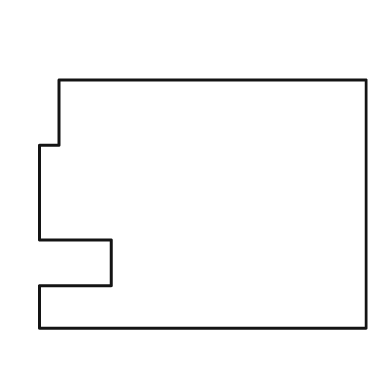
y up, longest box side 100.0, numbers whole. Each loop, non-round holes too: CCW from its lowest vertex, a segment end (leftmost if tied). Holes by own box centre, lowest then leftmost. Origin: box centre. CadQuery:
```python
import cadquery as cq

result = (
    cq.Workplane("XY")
    .moveTo(-50.0, -38.0)
    .lineTo(50.0, -38.0)
    .lineTo(50.0, 38.0)
    .lineTo(-44.0, 38.0)
    .lineTo(-44.0, 18.0)
    .lineTo(-50.0, 18.0)
    .lineTo(-50.0, -11.0)
    .lineTo(-28.0, -11.0)
    .lineTo(-28.0, -25.0)
    .lineTo(-50.0, -25.0)
    .close()
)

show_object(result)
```